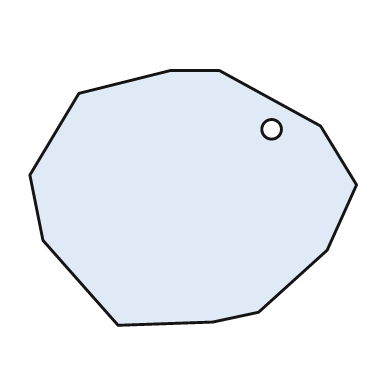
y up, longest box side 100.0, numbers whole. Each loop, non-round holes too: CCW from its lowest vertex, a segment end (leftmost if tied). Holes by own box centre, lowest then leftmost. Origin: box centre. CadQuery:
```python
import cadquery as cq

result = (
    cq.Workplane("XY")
    .moveTo(-23.0, -39.0)
    .lineTo(6.0, -38.0)
    .lineTo(20.0, -35.0)
    .lineTo(41.0, -16.0)
    .lineTo(50.0, 4.0)
    .lineTo(39.0, 22.0)
    .lineTo(8.0, 39.0)
    .lineTo(-7.0, 39.0)
    .lineTo(-35.0, 32.0)
    .lineTo(-50.0, 7.0)
    .lineTo(-46.0, -13.0)
    .close()
    .moveTo(24.0, 21.0)
    .circle(3.0)
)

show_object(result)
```